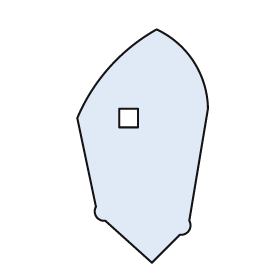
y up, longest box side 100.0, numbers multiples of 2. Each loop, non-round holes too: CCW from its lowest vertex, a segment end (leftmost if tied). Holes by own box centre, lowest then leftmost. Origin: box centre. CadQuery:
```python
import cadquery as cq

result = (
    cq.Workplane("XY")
    .moveTo(4.0, -50.0)
    .lineTo(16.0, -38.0)
    .threePointArc((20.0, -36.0), (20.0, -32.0))
    .lineTo(28.0, 16.0)
    .threePointArc((22.0, 36.0), (6.0, 50.0))
    .threePointArc((-14.0, 34.0), (-28.0, 12.0))
    .lineTo(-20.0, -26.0)
    .threePointArc((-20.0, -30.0), (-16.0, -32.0))
    .close()
    .moveTo(-10.0, 8.0)
    .lineTo(-2.0, 8.0)
    .lineTo(-2.0, 16.0)
    .lineTo(-10.0, 16.0)
    .close()
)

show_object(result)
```